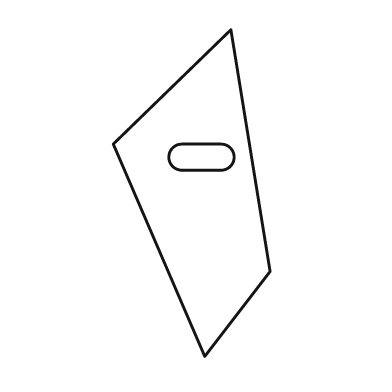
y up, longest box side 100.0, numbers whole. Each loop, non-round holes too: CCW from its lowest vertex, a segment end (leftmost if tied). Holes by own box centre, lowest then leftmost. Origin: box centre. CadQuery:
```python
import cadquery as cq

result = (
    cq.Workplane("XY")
    .moveTo(4.0, -50.0)
    .lineTo(24.0, -24.0)
    .lineTo(12.0, 50.0)
    .lineTo(-24.0, 15.0)
    .close()
    .moveTo(-3.0, 7.0)
    .lineTo(9.0, 7.0)
    .threePointArc((13.0, 11.0), (9.0, 15.0))
    .lineTo(-3.0, 15.0)
    .threePointArc((-7.0, 11.0), (-3.0, 7.0))
    .close()
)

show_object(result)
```